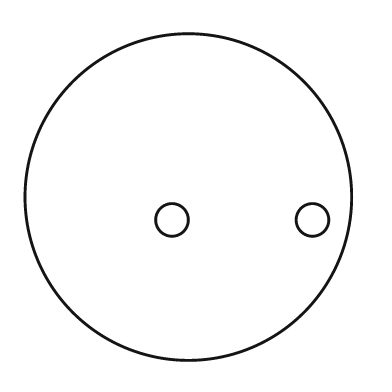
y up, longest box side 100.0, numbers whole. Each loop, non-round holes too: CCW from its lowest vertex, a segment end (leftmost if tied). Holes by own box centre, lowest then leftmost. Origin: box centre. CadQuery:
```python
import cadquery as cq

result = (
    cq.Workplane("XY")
    .moveTo(0.0, 0.0)
    .circle(50.0)
    .moveTo(-5.0, -7.0)
    .circle(5.0)
    .moveTo(38.0, -7.0)
    .circle(5.0)
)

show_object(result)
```